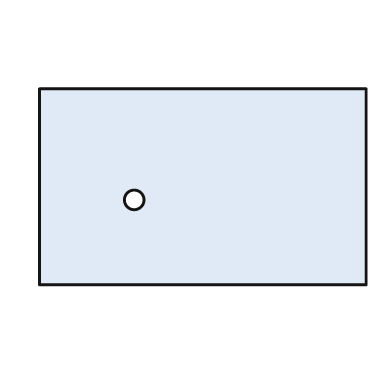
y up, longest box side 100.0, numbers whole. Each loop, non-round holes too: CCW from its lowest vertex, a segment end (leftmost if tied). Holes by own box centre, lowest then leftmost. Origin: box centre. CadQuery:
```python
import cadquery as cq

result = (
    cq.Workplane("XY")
    .moveTo(-50.0, -30.0)
    .lineTo(50.0, -30.0)
    .lineTo(50.0, 30.0)
    .lineTo(-50.0, 30.0)
    .close()
    .moveTo(-21.0, -4.0)
    .circle(3.0)
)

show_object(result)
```